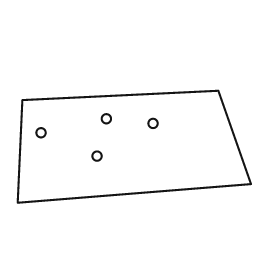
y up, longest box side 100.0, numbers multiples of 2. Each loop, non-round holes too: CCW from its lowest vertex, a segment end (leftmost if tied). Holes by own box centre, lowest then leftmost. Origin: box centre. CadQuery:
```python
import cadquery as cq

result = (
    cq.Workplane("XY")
    .moveTo(-50.0, -24.0)
    .lineTo(50.0, -16.0)
    .lineTo(36.0, 24.0)
    .lineTo(-48.0, 20.0)
    .close()
    .moveTo(-16.0, -4.0)
    .circle(2.0)
    .moveTo(-40.0, 6.0)
    .circle(2.0)
    .moveTo(8.0, 10.0)
    .circle(2.0)
    .moveTo(-12.0, 12.0)
    .circle(2.0)
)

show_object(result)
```